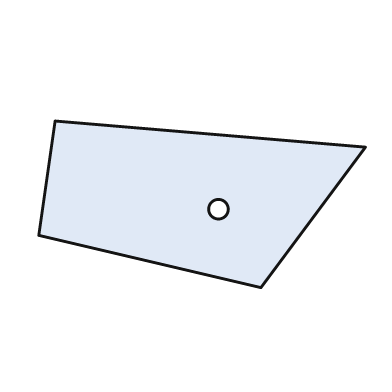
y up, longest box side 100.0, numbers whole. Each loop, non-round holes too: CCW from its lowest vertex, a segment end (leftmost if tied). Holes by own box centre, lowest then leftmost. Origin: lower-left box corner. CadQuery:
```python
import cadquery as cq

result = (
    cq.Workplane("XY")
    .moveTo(68.0, 0.0)
    .lineTo(100.0, 43.0)
    .lineTo(5.0, 51.0)
    .lineTo(0.0, 16.0)
    .close()
    .moveTo(55.0, 24.0)
    .circle(3.0)
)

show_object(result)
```